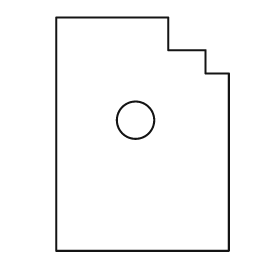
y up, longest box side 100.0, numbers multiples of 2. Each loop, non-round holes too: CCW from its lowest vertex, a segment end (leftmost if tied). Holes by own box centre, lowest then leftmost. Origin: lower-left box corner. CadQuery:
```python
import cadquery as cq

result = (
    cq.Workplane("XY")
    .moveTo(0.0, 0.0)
    .lineTo(74.0, 0.0)
    .lineTo(74.0, 76.0)
    .lineTo(64.0, 76.0)
    .lineTo(64.0, 86.0)
    .lineTo(48.0, 86.0)
    .lineTo(48.0, 100.0)
    .lineTo(0.0, 100.0)
    .close()
    .moveTo(34.0, 56.0)
    .circle(8.0)
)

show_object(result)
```